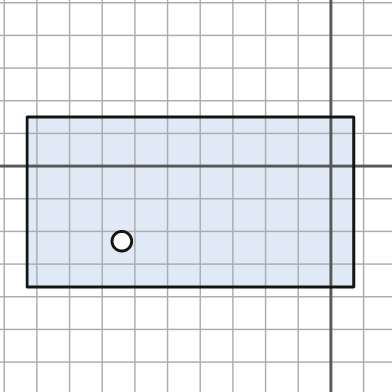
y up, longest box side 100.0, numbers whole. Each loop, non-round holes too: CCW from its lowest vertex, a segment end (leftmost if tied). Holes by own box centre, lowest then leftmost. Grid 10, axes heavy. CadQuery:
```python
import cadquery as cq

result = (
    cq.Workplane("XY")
    .moveTo(-93.0, -37.0)
    .lineTo(7.0, -37.0)
    .lineTo(7.0, 15.0)
    .lineTo(-93.0, 15.0)
    .close()
    .moveTo(-64.0, -23.0)
    .circle(3.0)
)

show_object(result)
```